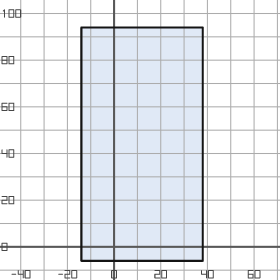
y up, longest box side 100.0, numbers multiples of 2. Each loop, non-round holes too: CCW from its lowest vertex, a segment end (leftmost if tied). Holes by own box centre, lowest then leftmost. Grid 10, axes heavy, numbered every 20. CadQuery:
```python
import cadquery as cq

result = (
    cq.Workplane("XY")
    .moveTo(-14.0, -6.0)
    .lineTo(38.0, -6.0)
    .lineTo(38.0, 94.0)
    .lineTo(-14.0, 94.0)
    .close()
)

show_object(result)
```